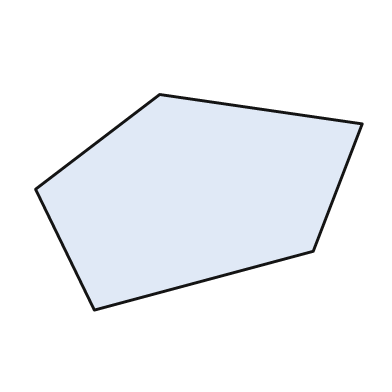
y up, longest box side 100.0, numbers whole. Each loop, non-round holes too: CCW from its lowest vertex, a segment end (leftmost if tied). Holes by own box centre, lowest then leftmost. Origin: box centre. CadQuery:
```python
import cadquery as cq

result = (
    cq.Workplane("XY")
    .moveTo(-32.0, -33.0)
    .lineTo(35.0, -15.0)
    .lineTo(50.0, 24.0)
    .lineTo(-12.0, 33.0)
    .lineTo(-50.0, 4.0)
    .close()
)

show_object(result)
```